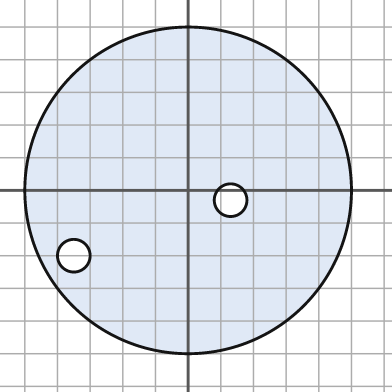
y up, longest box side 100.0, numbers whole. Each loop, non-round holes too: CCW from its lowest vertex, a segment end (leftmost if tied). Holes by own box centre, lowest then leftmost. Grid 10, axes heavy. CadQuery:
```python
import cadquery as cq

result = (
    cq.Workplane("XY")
    .moveTo(0.0, 0.0)
    .circle(50.0)
    .moveTo(-35.0, -20.0)
    .circle(5.0)
    .moveTo(13.0, -3.0)
    .circle(5.0)
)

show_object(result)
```